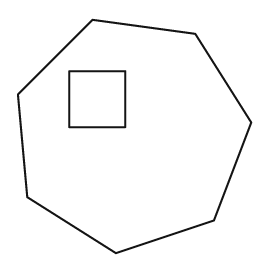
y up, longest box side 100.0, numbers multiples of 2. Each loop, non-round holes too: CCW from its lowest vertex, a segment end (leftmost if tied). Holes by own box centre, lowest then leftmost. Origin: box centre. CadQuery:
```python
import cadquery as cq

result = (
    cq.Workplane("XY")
    .moveTo(-8.0, -50.0)
    .lineTo(34.0, -36.0)
    .lineTo(50.0, 6.0)
    .lineTo(26.0, 44.0)
    .lineTo(-18.0, 50.0)
    .lineTo(-50.0, 18.0)
    .lineTo(-46.0, -26.0)
    .close()
    .moveTo(-28.0, 4.0)
    .lineTo(-4.0, 4.0)
    .lineTo(-4.0, 28.0)
    .lineTo(-28.0, 28.0)
    .close()
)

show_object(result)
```